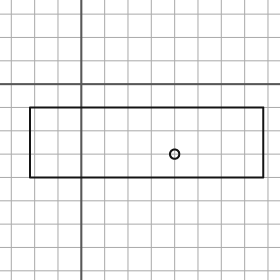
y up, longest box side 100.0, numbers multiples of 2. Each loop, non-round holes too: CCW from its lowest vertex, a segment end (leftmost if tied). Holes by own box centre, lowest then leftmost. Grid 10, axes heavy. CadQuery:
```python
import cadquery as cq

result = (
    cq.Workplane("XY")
    .moveTo(-22.0, -40.0)
    .lineTo(78.0, -40.0)
    .lineTo(78.0, -10.0)
    .lineTo(-22.0, -10.0)
    .close()
    .moveTo(40.0, -30.0)
    .circle(2.0)
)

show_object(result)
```